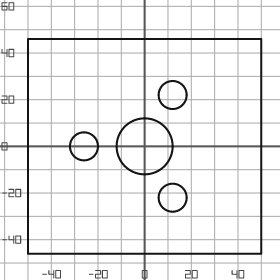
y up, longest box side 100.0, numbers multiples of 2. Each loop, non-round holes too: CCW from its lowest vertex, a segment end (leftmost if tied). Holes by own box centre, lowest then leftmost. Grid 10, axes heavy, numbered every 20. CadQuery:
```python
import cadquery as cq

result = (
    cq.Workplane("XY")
    .moveTo(-50.0, -46.0)
    .lineTo(50.0, -46.0)
    .lineTo(50.0, 46.0)
    .lineTo(-50.0, 46.0)
    .close()
    .moveTo(12.0, -22.0)
    .circle(6.0)
    .moveTo(-26.0, 0.0)
    .circle(6.0)
    .moveTo(0.0, 0.0)
    .circle(12.0)
    .moveTo(12.0, 22.0)
    .circle(6.0)
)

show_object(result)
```